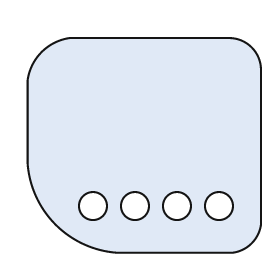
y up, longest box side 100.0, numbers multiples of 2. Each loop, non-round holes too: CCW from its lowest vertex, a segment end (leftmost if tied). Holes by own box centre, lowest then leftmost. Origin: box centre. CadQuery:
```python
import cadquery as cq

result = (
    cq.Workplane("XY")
    .moveTo(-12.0, -46.0)
    .lineTo(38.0, -46.0)
    .threePointArc((46.0, -42.0), (50.0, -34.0))
    .lineTo(50.0, 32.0)
    .threePointArc((46.0, 42.0), (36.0, 46.0))
    .lineTo(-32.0, 46.0)
    .threePointArc((-44.0, 40.0), (-50.0, 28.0))
    .lineTo(-50.0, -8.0)
    .threePointArc((-38.0, -34.0), (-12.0, -46.0))
    .close()
    .moveTo(-22.0, -26.0)
    .circle(6.0)
    .moveTo(-4.0, -26.0)
    .circle(6.0)
    .moveTo(14.0, -26.0)
    .circle(6.0)
    .moveTo(32.0, -26.0)
    .circle(6.0)
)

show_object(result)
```